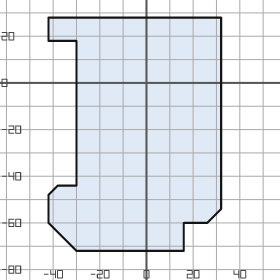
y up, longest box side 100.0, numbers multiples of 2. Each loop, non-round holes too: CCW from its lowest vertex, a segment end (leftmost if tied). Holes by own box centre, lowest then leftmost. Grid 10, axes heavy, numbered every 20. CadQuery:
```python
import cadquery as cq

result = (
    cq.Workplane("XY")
    .moveTo(-30.0, -72.0)
    .lineTo(16.0, -72.0)
    .lineTo(16.0, -60.0)
    .lineTo(26.0, -60.0)
    .lineTo(32.0, -54.0)
    .lineTo(32.0, 28.0)
    .lineTo(-42.0, 28.0)
    .lineTo(-42.0, 18.0)
    .lineTo(-30.0, 18.0)
    .lineTo(-30.0, -44.0)
    .lineTo(-38.0, -44.0)
    .lineTo(-42.0, -48.0)
    .lineTo(-42.0, -60.0)
    .close()
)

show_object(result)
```